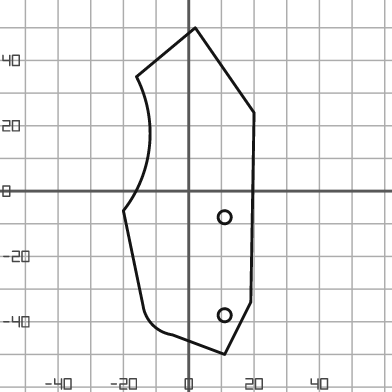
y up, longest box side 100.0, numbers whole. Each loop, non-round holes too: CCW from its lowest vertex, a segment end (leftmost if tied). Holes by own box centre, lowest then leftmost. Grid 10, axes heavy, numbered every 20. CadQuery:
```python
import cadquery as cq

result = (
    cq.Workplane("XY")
    .moveTo(11.0, -50.0)
    .lineTo(19.0, -34.0)
    .lineTo(20.0, 24.0)
    .lineTo(2.0, 50.0)
    .lineTo(-16.0, 35.0)
    .threePointArc((-12.0, 14.0), (-20.0, -6.0))
    .lineTo(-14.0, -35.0)
    .threePointArc((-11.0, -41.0), (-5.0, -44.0))
    .close()
    .moveTo(11.0, -38.0)
    .circle(2.0)
    .moveTo(11.0, -8.0)
    .circle(2.0)
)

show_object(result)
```